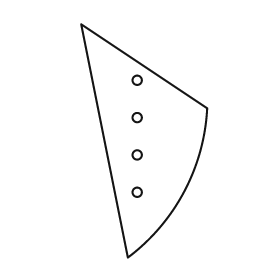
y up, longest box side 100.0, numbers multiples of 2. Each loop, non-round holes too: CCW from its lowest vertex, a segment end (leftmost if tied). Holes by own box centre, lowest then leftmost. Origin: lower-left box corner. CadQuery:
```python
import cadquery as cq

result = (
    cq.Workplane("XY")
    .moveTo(20.0, 0.0)
    .threePointArc((44.0, 28.0), (54.0, 64.0))
    .lineTo(0.0, 100.0)
    .close()
    .moveTo(24.0, 28.0)
    .circle(2.0)
    .moveTo(24.0, 44.0)
    .circle(2.0)
    .moveTo(24.0, 60.0)
    .circle(2.0)
    .moveTo(24.0, 76.0)
    .circle(2.0)
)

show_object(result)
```